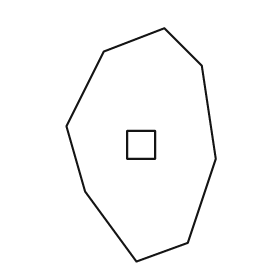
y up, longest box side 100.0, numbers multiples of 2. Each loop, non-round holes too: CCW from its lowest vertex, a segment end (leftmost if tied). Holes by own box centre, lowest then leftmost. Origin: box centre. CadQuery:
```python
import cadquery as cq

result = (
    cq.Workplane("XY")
    .moveTo(-2.0, -50.0)
    .lineTo(20.0, -42.0)
    .lineTo(32.0, -6.0)
    .lineTo(26.0, 34.0)
    .lineTo(10.0, 50.0)
    .lineTo(-16.0, 40.0)
    .lineTo(-32.0, 8.0)
    .lineTo(-24.0, -20.0)
    .close()
    .moveTo(-6.0, -6.0)
    .lineTo(6.0, -6.0)
    .lineTo(6.0, 6.0)
    .lineTo(-6.0, 6.0)
    .close()
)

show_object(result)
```